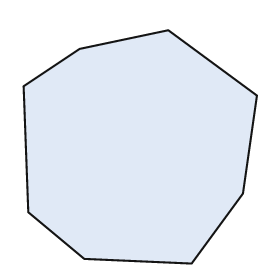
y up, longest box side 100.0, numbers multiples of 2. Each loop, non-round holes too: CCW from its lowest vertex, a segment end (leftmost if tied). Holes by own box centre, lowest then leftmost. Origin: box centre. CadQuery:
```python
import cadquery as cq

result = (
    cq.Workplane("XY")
    .moveTo(22.0, -50.0)
    .lineTo(44.0, -20.0)
    .lineTo(50.0, 22.0)
    .lineTo(12.0, 50.0)
    .lineTo(-26.0, 42.0)
    .lineTo(-50.0, 26.0)
    .lineTo(-48.0, -28.0)
    .lineTo(-24.0, -48.0)
    .close()
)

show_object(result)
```